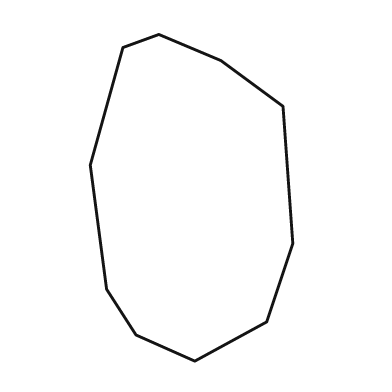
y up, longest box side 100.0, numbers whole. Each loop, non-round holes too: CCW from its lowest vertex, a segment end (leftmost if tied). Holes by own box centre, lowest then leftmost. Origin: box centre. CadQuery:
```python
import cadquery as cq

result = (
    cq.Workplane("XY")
    .moveTo(1.0, -50.0)
    .lineTo(23.0, -38.0)
    .lineTo(31.0, -14.0)
    .lineTo(28.0, 28.0)
    .lineTo(9.0, 42.0)
    .lineTo(-10.0, 50.0)
    .lineTo(-21.0, 46.0)
    .lineTo(-31.0, 10.0)
    .lineTo(-26.0, -28.0)
    .lineTo(-17.0, -42.0)
    .close()
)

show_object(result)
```